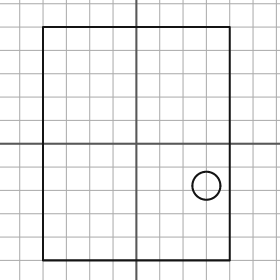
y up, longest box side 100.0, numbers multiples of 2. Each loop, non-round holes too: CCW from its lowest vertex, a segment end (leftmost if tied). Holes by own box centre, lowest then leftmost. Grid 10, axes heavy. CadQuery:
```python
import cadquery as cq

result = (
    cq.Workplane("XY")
    .moveTo(-40.0, -50.0)
    .lineTo(40.0, -50.0)
    .lineTo(40.0, 50.0)
    .lineTo(-40.0, 50.0)
    .close()
    .moveTo(30.0, -18.0)
    .circle(6.0)
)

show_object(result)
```